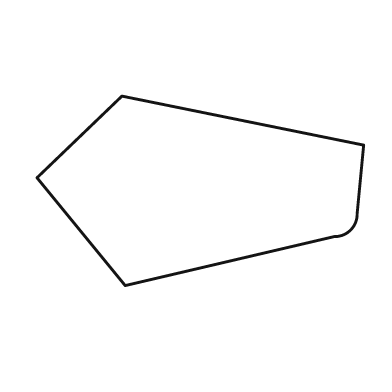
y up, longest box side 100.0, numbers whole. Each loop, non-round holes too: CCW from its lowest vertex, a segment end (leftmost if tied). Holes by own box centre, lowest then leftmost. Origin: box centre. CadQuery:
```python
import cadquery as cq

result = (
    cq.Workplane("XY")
    .moveTo(-23.0, -29.0)
    .lineTo(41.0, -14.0)
    .threePointArc((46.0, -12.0), (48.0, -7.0))
    .lineTo(50.0, 14.0)
    .lineTo(-24.0, 29.0)
    .lineTo(-50.0, 4.0)
    .close()
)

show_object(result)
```